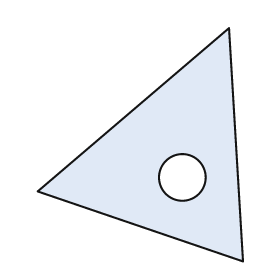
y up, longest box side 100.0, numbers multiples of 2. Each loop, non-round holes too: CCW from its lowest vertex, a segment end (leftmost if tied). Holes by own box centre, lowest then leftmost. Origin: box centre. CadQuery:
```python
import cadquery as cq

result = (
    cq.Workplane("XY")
    .moveTo(44.0, -50.0)
    .lineTo(38.0, 50.0)
    .lineTo(-44.0, -20.0)
    .close()
    .moveTo(18.0, -14.0)
    .circle(10.0)
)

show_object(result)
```